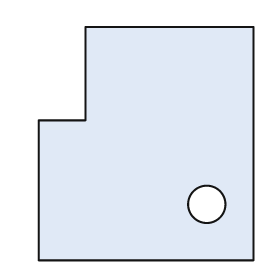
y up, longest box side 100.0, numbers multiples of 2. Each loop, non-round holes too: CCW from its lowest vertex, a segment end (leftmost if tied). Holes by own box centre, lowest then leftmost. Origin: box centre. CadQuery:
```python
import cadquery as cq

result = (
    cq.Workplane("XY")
    .moveTo(-46.0, -50.0)
    .lineTo(46.0, -50.0)
    .lineTo(46.0, 50.0)
    .lineTo(-26.0, 50.0)
    .lineTo(-26.0, 10.0)
    .lineTo(-46.0, 10.0)
    .close()
    .moveTo(26.0, -26.0)
    .circle(8.0)
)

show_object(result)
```